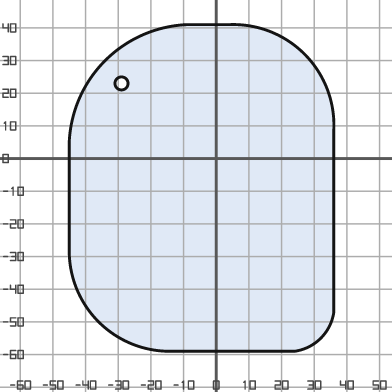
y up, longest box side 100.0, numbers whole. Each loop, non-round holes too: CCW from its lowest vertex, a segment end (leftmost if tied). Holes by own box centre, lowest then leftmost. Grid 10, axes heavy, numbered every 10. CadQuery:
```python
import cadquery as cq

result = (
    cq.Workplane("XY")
    .moveTo(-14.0, -59.0)
    .lineTo(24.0, -59.0)
    .threePointArc((32.0, -55.0), (36.0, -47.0))
    .lineTo(36.0, 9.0)
    .threePointArc((27.0, 32.0), (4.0, 41.0))
    .lineTo(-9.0, 41.0)
    .threePointArc((-34.0, 30.0), (-45.0, 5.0))
    .lineTo(-45.0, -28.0)
    .threePointArc((-36.0, -50.0), (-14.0, -59.0))
    .close()
    .moveTo(-29.0, 23.0)
    .circle(2.0)
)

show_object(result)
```